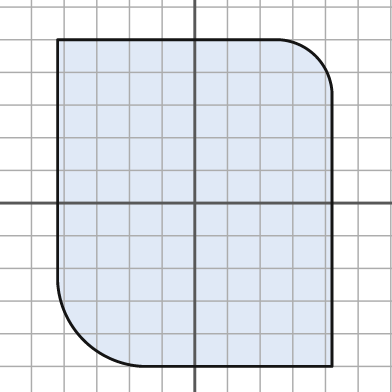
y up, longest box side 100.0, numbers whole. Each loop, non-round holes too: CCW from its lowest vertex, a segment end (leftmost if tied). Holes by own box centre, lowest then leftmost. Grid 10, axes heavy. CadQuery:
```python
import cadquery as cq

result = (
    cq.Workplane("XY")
    .moveTo(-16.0, -50.0)
    .lineTo(42.0, -50.0)
    .lineTo(42.0, 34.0)
    .threePointArc((37.0, 45.0), (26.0, 50.0))
    .lineTo(-42.0, 50.0)
    .lineTo(-42.0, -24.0)
    .threePointArc((-34.0, -42.0), (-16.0, -50.0))
    .close()
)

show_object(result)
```